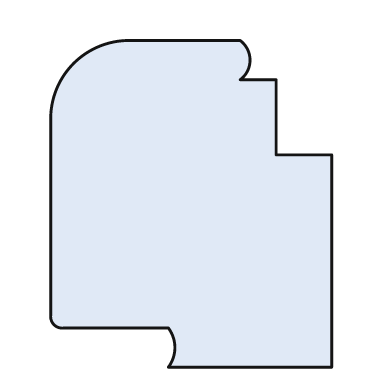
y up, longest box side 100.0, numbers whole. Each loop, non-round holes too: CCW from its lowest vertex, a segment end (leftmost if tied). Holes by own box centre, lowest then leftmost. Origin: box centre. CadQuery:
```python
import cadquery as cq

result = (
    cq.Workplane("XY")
    .moveTo(-7.0, -50.0)
    .lineTo(43.0, -50.0)
    .lineTo(43.0, 15.0)
    .lineTo(26.0, 15.0)
    .lineTo(26.0, 38.0)
    .lineTo(15.0, 38.0)
    .threePointArc((18.0, 44.0), (15.0, 50.0))
    .lineTo(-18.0, 50.0)
    .threePointArc((-36.0, 43.0), (-43.0, 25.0))
    .lineTo(-43.0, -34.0)
    .threePointArc((-42.0, -37.0), (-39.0, -38.0))
    .lineTo(-7.0, -38.0)
    .threePointArc((-5.0, -44.0), (-7.0, -50.0))
    .close()
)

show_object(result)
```